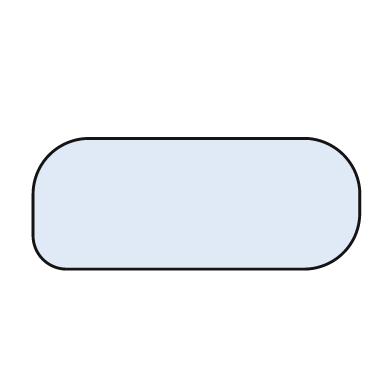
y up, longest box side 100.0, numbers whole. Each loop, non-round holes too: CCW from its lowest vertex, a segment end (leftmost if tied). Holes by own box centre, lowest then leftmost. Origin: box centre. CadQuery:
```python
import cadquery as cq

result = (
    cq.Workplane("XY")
    .moveTo(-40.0, -20.0)
    .lineTo(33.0, -20.0)
    .threePointArc((45.0, -15.0), (50.0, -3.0))
    .lineTo(50.0, 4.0)
    .threePointArc((45.0, 15.0), (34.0, 20.0))
    .lineTo(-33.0, 20.0)
    .threePointArc((-45.0, 15.0), (-50.0, 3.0))
    .lineTo(-50.0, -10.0)
    .threePointArc((-47.0, -17.0), (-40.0, -20.0))
    .close()
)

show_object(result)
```